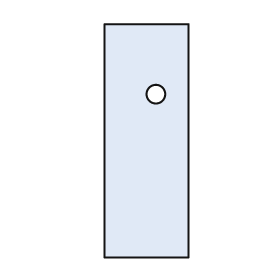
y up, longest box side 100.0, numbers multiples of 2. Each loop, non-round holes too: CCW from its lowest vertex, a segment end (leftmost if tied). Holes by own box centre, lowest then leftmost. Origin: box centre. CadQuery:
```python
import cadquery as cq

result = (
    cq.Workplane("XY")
    .moveTo(-18.0, -50.0)
    .lineTo(18.0, -50.0)
    .lineTo(18.0, 50.0)
    .lineTo(-18.0, 50.0)
    .close()
    .moveTo(4.0, 20.0)
    .circle(4.0)
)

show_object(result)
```